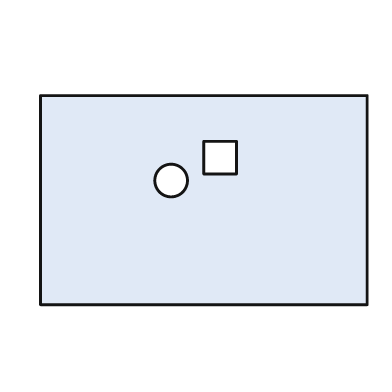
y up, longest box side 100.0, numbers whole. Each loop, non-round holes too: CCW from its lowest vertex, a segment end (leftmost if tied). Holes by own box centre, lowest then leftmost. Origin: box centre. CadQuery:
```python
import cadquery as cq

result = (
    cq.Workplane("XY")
    .moveTo(-50.0, -32.0)
    .lineTo(50.0, -32.0)
    .lineTo(50.0, 32.0)
    .lineTo(-50.0, 32.0)
    .close()
    .moveTo(-10.0, 6.0)
    .circle(5.0)
    .moveTo(0.0, 8.0)
    .lineTo(10.0, 8.0)
    .lineTo(10.0, 18.0)
    .lineTo(0.0, 18.0)
    .close()
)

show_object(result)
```